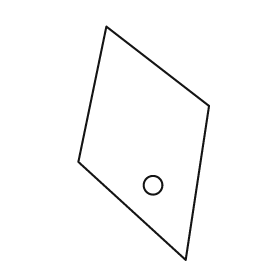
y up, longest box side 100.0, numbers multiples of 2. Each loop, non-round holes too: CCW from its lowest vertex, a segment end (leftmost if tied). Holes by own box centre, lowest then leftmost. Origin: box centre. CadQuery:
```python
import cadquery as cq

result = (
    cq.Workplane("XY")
    .moveTo(18.0, -50.0)
    .lineTo(28.0, 16.0)
    .lineTo(-16.0, 50.0)
    .lineTo(-28.0, -8.0)
    .close()
    .moveTo(4.0, -18.0)
    .circle(4.0)
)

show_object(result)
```